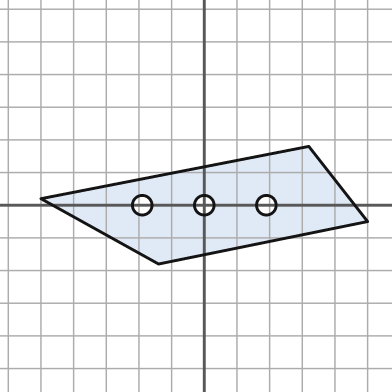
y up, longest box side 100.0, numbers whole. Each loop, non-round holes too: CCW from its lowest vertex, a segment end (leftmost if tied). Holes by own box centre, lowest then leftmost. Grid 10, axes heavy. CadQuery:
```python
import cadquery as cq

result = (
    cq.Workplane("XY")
    .moveTo(-14.0, -18.0)
    .lineTo(50.0, -5.0)
    .lineTo(32.0, 18.0)
    .lineTo(-50.0, 2.0)
    .close()
    .moveTo(-19.0, 0.0)
    .circle(3.0)
    .moveTo(0.0, 0.0)
    .circle(3.0)
    .moveTo(19.0, 0.0)
    .circle(3.0)
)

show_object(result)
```